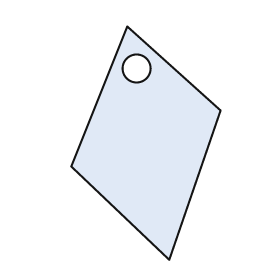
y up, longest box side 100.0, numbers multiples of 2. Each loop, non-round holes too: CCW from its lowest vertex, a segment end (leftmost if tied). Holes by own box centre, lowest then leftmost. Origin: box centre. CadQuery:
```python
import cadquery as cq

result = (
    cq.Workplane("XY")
    .moveTo(10.0, -50.0)
    .lineTo(32.0, 14.0)
    .lineTo(-8.0, 50.0)
    .lineTo(-32.0, -10.0)
    .close()
    .moveTo(-4.0, 32.0)
    .circle(6.0)
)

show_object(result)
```